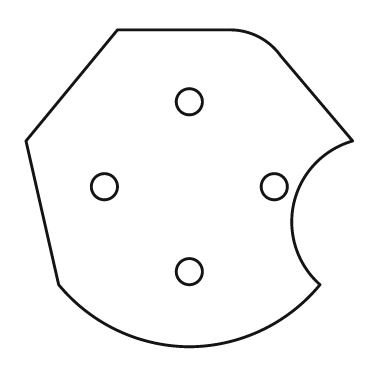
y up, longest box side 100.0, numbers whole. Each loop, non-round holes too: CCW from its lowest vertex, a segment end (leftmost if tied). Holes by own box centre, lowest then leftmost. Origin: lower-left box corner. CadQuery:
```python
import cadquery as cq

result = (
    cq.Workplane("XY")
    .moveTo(50.0, 0.0)
    .threePointArc((72.0, 5.0), (90.0, 19.0))
    .threePointArc((82.0, 44.0), (100.0, 63.0))
    .lineTo(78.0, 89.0)
    .threePointArc((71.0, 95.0), (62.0, 97.0))
    .lineTo(28.0, 97.0)
    .lineTo(0.0, 63.0)
    .lineTo(10.0, 19.0)
    .threePointArc((28.0, 5.0), (50.0, 0.0))
    .close()
    .moveTo(50.0, 23.0)
    .circle(4.0)
    .moveTo(24.0, 49.0)
    .circle(4.0)
    .moveTo(76.0, 49.0)
    .circle(4.0)
    .moveTo(50.0, 75.0)
    .circle(4.0)
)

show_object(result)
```